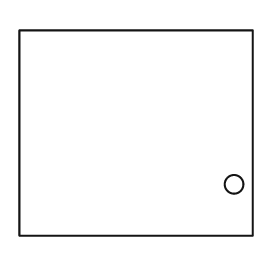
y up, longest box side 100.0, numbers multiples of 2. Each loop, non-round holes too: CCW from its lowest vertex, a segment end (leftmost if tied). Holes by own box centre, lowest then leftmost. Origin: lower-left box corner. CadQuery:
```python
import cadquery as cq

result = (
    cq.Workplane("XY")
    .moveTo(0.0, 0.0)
    .lineTo(100.0, 0.0)
    .lineTo(100.0, 88.0)
    .lineTo(0.0, 88.0)
    .close()
    .moveTo(92.0, 22.0)
    .circle(4.0)
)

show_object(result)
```